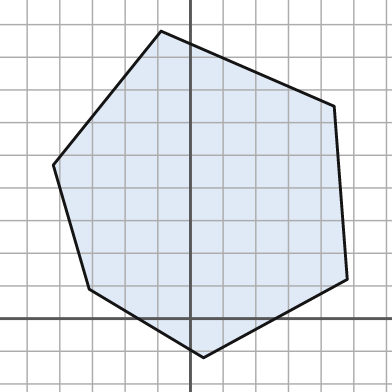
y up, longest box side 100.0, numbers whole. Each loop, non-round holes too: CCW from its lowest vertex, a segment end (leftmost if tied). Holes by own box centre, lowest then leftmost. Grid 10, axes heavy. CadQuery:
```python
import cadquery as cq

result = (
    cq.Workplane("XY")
    .moveTo(4.0, -12.0)
    .lineTo(48.0, 12.0)
    .lineTo(44.0, 65.0)
    .lineTo(-9.0, 88.0)
    .lineTo(-42.0, 47.0)
    .lineTo(-31.0, 9.0)
    .close()
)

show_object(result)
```